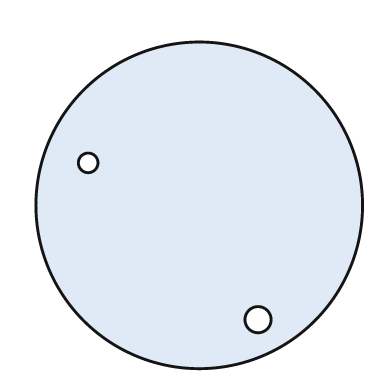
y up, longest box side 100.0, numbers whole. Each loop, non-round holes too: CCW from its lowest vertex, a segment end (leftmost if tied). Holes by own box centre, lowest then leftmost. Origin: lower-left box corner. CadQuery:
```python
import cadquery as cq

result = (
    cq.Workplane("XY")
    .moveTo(50.0, 50.0)
    .circle(50.0)
    .moveTo(68.0, 15.0)
    .circle(4.0)
    .moveTo(16.0, 63.0)
    .circle(3.0)
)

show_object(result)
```